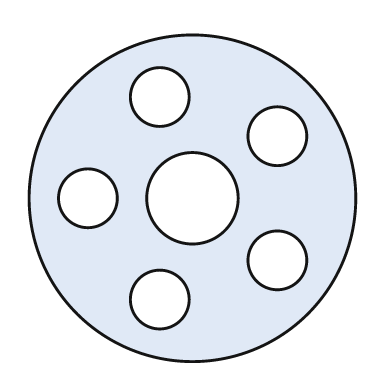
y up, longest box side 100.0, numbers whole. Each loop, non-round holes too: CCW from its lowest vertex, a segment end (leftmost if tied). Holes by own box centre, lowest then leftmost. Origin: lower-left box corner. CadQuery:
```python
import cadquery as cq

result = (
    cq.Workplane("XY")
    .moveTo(50.0, 50.0)
    .circle(50.0)
    .moveTo(40.0, 19.0)
    .circle(9.0)
    .moveTo(76.0, 31.0)
    .circle(9.0)
    .moveTo(18.0, 50.0)
    .circle(9.0)
    .moveTo(50.0, 50.0)
    .circle(14.0)
    .moveTo(76.0, 69.0)
    .circle(9.0)
    .moveTo(40.0, 81.0)
    .circle(9.0)
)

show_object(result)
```